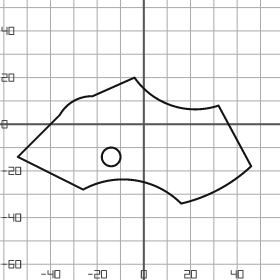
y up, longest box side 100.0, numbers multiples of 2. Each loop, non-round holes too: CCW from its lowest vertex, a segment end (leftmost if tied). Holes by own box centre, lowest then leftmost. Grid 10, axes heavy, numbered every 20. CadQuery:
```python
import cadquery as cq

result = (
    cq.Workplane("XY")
    .moveTo(16.0, -34.0)
    .threePointArc((32.0, -28.0), (46.0, -18.0))
    .lineTo(32.0, 8.0)
    .threePointArc((12.0, 8.0), (-4.0, 20.0))
    .lineTo(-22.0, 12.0)
    .threePointArc((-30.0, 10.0), (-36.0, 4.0))
    .lineTo(-54.0, -14.0)
    .lineTo(-26.0, -28.0)
    .threePointArc((-4.0, -24.0), (16.0, -34.0))
    .close()
    .moveTo(-14.0, -14.0)
    .circle(4.0)
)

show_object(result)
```